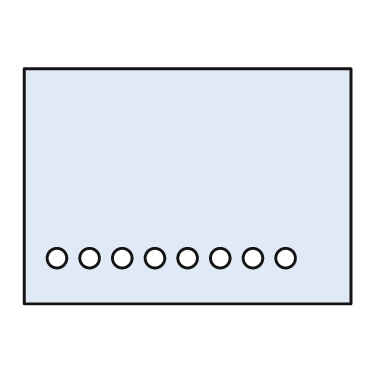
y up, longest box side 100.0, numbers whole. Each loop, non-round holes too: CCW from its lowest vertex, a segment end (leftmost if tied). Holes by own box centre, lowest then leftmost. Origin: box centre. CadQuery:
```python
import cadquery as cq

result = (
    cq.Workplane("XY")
    .moveTo(-50.0, -36.0)
    .lineTo(50.0, -36.0)
    .lineTo(50.0, 36.0)
    .lineTo(-50.0, 36.0)
    .close()
    .moveTo(-40.0, -22.0)
    .circle(3.0)
    .moveTo(-30.0, -22.0)
    .circle(3.0)
    .moveTo(-20.0, -22.0)
    .circle(3.0)
    .moveTo(-10.0, -22.0)
    .circle(3.0)
    .moveTo(0.0, -22.0)
    .circle(3.0)
    .moveTo(10.0, -22.0)
    .circle(3.0)
    .moveTo(20.0, -22.0)
    .circle(3.0)
    .moveTo(30.0, -22.0)
    .circle(3.0)
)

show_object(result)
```